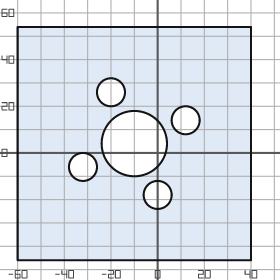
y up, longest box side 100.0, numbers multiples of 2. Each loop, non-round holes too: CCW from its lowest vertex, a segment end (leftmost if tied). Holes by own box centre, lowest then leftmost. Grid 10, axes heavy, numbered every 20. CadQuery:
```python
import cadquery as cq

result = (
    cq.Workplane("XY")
    .moveTo(-60.0, -46.0)
    .lineTo(40.0, -46.0)
    .lineTo(40.0, 54.0)
    .lineTo(-60.0, 54.0)
    .close()
    .moveTo(0.0, -18.0)
    .circle(6.0)
    .moveTo(-32.0, -6.0)
    .circle(6.0)
    .moveTo(-10.0, 4.0)
    .circle(14.0)
    .moveTo(12.0, 14.0)
    .circle(6.0)
    .moveTo(-20.0, 26.0)
    .circle(6.0)
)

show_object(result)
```